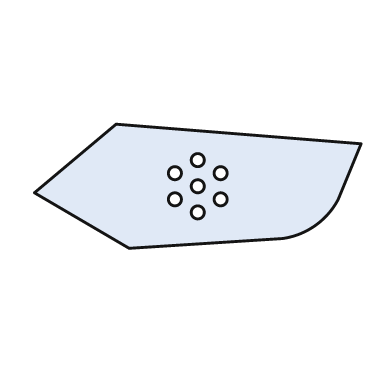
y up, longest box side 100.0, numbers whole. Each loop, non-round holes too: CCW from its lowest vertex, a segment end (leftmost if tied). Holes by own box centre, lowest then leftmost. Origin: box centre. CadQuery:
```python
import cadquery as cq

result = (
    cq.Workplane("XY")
    .moveTo(-21.0, -19.0)
    .lineTo(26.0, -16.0)
    .threePointArc((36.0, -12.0), (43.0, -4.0))
    .lineTo(50.0, 13.0)
    .lineTo(-25.0, 19.0)
    .lineTo(-50.0, -2.0)
    .close()
    .moveTo(0.0, -8.0)
    .circle(2.0)
    .moveTo(-7.0, -4.0)
    .circle(2.0)
    .moveTo(7.0, -4.0)
    .circle(2.0)
    .moveTo(0.0, 0.0)
    .circle(2.0)
    .moveTo(-7.0, 4.0)
    .circle(2.0)
    .moveTo(7.0, 4.0)
    .circle(2.0)
    .moveTo(0.0, 8.0)
    .circle(2.0)
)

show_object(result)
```